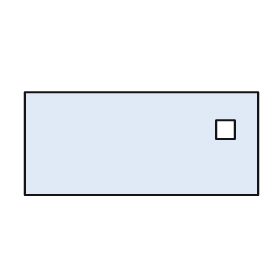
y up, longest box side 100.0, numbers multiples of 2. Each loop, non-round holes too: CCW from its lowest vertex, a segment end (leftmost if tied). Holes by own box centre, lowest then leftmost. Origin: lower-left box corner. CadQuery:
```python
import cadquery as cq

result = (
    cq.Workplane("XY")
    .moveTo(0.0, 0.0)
    .lineTo(100.0, 0.0)
    .lineTo(100.0, 44.0)
    .lineTo(0.0, 44.0)
    .close()
    .moveTo(82.0, 24.0)
    .lineTo(90.0, 24.0)
    .lineTo(90.0, 32.0)
    .lineTo(82.0, 32.0)
    .close()
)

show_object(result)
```